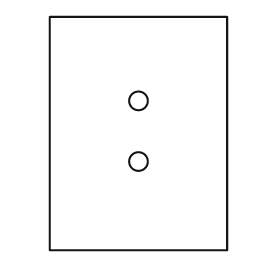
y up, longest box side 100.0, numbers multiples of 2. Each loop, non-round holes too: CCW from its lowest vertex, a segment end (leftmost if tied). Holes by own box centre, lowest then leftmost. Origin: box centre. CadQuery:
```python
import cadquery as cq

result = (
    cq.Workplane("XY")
    .moveTo(-38.0, -50.0)
    .lineTo(38.0, -50.0)
    .lineTo(38.0, 50.0)
    .lineTo(-38.0, 50.0)
    .close()
    .moveTo(0.0, -12.0)
    .circle(4.0)
    .moveTo(0.0, 14.0)
    .circle(4.0)
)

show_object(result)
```